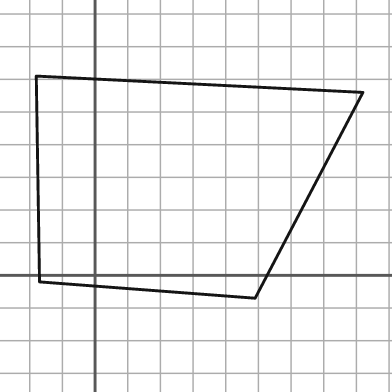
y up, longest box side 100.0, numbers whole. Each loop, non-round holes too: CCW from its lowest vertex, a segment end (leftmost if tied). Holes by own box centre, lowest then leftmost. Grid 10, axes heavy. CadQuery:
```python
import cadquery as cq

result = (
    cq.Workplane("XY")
    .moveTo(49.0, -7.0)
    .lineTo(82.0, 56.0)
    .lineTo(-18.0, 61.0)
    .lineTo(-17.0, -2.0)
    .close()
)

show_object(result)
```